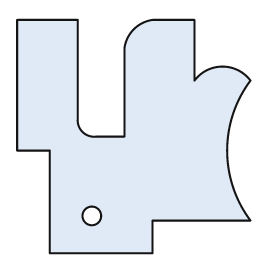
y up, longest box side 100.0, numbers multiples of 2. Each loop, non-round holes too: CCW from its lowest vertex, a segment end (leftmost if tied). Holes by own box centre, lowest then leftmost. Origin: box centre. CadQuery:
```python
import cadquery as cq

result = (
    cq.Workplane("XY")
    .moveTo(-36.0, -50.0)
    .lineTo(8.0, -50.0)
    .lineTo(8.0, -36.0)
    .lineTo(50.0, -36.0)
    .threePointArc((40.0, -6.0), (50.0, 24.0))
    .threePointArc((38.0, 30.0), (26.0, 24.0))
    .lineTo(26.0, 50.0)
    .lineTo(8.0, 50.0)
    .threePointArc((0.0, 46.0), (-4.0, 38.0))
    .lineTo(-4.0, 0.0)
    .lineTo(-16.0, 0.0)
    .threePointArc((-22.0, 2.0), (-24.0, 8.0))
    .lineTo(-24.0, 50.0)
    .lineTo(-50.0, 50.0)
    .lineTo(-50.0, -6.0)
    .lineTo(-36.0, -6.0)
    .close()
    .moveTo(-18.0, -34.0)
    .circle(4.0)
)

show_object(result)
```